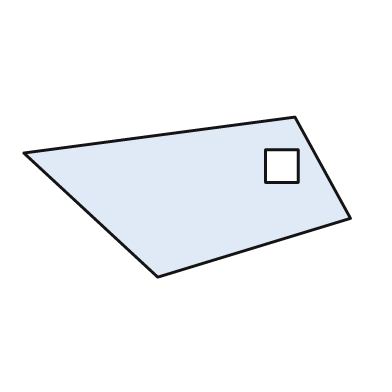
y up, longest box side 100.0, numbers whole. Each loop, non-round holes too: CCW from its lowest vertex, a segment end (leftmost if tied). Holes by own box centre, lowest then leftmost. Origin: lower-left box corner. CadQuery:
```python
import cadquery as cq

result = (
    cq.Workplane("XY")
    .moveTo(41.0, 0.0)
    .lineTo(100.0, 18.0)
    .lineTo(83.0, 49.0)
    .lineTo(0.0, 38.0)
    .close()
    .moveTo(74.0, 29.0)
    .lineTo(84.0, 29.0)
    .lineTo(84.0, 39.0)
    .lineTo(74.0, 39.0)
    .close()
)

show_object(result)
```